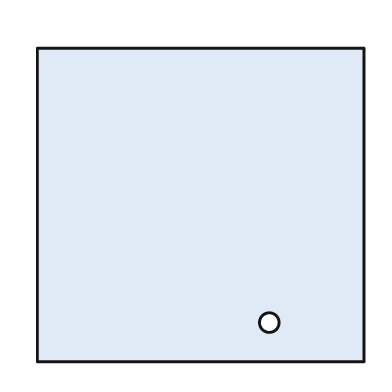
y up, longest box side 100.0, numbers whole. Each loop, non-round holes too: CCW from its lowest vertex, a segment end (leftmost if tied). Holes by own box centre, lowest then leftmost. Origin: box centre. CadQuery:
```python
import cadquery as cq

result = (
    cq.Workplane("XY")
    .moveTo(-50.0, -48.0)
    .lineTo(50.0, -48.0)
    .lineTo(50.0, 48.0)
    .lineTo(-50.0, 48.0)
    .close()
    .moveTo(21.0, -36.0)
    .circle(3.0)
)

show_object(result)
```